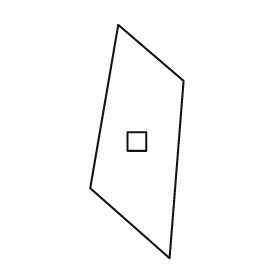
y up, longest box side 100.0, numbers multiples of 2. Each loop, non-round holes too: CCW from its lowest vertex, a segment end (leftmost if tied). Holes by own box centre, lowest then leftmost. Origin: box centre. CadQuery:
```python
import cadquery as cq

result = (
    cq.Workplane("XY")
    .moveTo(14.0, -50.0)
    .lineTo(20.0, 26.0)
    .lineTo(-8.0, 50.0)
    .lineTo(-20.0, -20.0)
    .close()
    .moveTo(-4.0, -4.0)
    .lineTo(4.0, -4.0)
    .lineTo(4.0, 4.0)
    .lineTo(-4.0, 4.0)
    .close()
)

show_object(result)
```